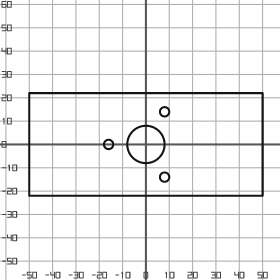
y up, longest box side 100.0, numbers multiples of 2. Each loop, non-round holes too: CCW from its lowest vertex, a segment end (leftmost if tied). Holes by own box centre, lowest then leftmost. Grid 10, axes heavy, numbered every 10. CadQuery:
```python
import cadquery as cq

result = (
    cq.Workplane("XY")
    .moveTo(-50.0, -22.0)
    .lineTo(50.0, -22.0)
    .lineTo(50.0, 22.0)
    .lineTo(-50.0, 22.0)
    .close()
    .moveTo(8.0, -14.0)
    .circle(2.0)
    .moveTo(-16.0, 0.0)
    .circle(2.0)
    .moveTo(0.0, 0.0)
    .circle(8.0)
    .moveTo(8.0, 14.0)
    .circle(2.0)
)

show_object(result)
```